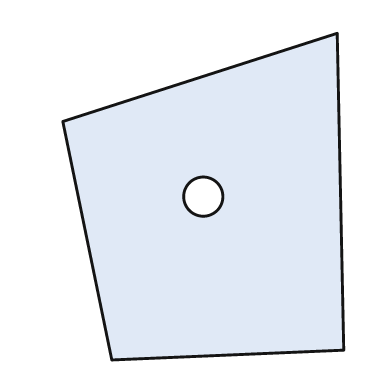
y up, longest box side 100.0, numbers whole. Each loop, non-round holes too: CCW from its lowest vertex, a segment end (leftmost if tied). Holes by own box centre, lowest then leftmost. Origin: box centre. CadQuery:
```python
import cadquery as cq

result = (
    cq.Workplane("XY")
    .moveTo(-28.0, -50.0)
    .lineTo(43.0, -47.0)
    .lineTo(41.0, 50.0)
    .lineTo(-43.0, 23.0)
    .close()
    .moveTo(0.0, 0.0)
    .circle(6.0)
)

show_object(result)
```